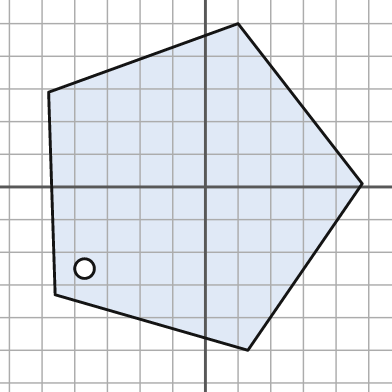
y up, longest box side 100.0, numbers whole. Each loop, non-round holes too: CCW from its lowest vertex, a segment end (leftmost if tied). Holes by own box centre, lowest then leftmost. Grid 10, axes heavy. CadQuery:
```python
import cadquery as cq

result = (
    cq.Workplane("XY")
    .moveTo(13.0, -50.0)
    .lineTo(48.0, 1.0)
    .lineTo(10.0, 50.0)
    .lineTo(-48.0, 29.0)
    .lineTo(-46.0, -33.0)
    .close()
    .moveTo(-37.0, -25.0)
    .circle(3.0)
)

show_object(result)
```